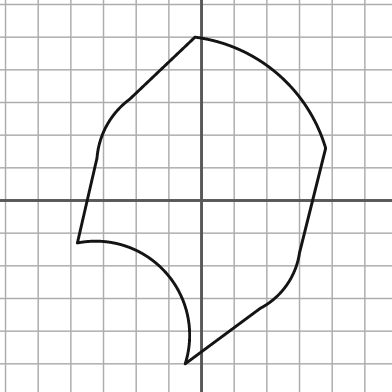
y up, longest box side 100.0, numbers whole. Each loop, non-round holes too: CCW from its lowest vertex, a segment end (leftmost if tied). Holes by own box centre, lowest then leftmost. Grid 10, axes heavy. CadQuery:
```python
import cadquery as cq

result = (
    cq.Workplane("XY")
    .moveTo(-5.0, -50.0)
    .lineTo(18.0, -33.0)
    .threePointArc((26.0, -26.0), (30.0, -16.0))
    .lineTo(38.0, 16.0)
    .threePointArc((23.0, 39.0), (-2.0, 50.0))
    .lineTo(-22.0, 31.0)
    .threePointArc((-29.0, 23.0), (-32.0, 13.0))
    .lineTo(-38.0, -13.0)
    .threePointArc((-11.0, -22.0), (-5.0, -50.0))
    .close()
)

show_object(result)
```